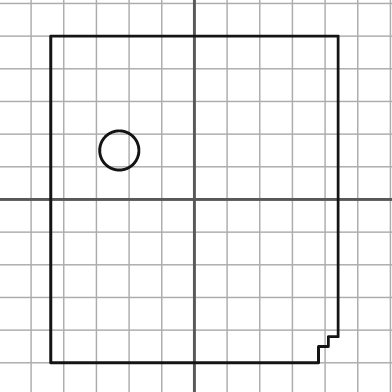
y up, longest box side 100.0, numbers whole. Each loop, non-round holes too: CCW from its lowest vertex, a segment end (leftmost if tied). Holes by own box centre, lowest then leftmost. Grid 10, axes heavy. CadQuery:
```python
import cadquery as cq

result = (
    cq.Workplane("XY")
    .moveTo(-44.0, -50.0)
    .lineTo(38.0, -50.0)
    .lineTo(38.0, -45.0)
    .lineTo(41.0, -45.0)
    .lineTo(41.0, -42.0)
    .lineTo(44.0, -42.0)
    .lineTo(44.0, 50.0)
    .lineTo(-44.0, 50.0)
    .close()
    .moveTo(-23.0, 15.0)
    .circle(6.0)
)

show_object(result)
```